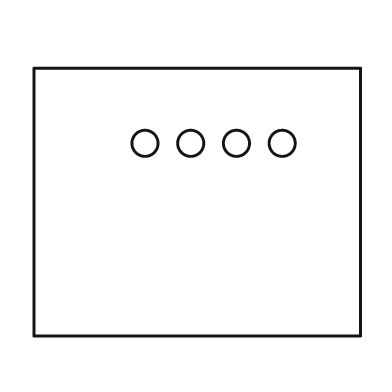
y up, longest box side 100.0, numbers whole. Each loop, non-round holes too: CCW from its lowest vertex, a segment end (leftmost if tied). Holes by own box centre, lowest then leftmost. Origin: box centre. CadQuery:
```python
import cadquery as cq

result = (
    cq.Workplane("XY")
    .moveTo(-50.0, -41.0)
    .lineTo(50.0, -41.0)
    .lineTo(50.0, 41.0)
    .lineTo(-50.0, 41.0)
    .close()
    .moveTo(-16.0, 18.0)
    .circle(4.0)
    .moveTo(-2.0, 18.0)
    .circle(4.0)
    .moveTo(12.0, 18.0)
    .circle(4.0)
    .moveTo(26.0, 18.0)
    .circle(4.0)
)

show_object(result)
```